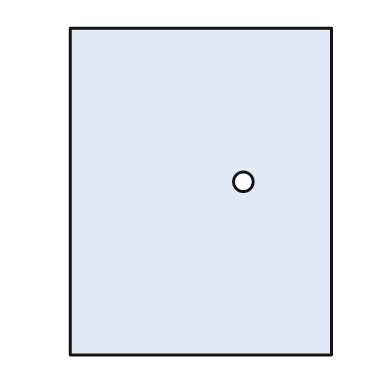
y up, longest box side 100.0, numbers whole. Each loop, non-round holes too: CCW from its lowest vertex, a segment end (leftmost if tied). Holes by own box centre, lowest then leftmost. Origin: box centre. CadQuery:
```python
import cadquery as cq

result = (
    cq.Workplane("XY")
    .moveTo(-40.0, -50.0)
    .lineTo(40.0, -50.0)
    .lineTo(40.0, 50.0)
    .lineTo(-40.0, 50.0)
    .close()
    .moveTo(13.0, 3.0)
    .circle(3.0)
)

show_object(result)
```